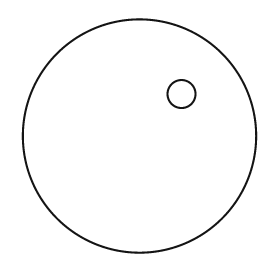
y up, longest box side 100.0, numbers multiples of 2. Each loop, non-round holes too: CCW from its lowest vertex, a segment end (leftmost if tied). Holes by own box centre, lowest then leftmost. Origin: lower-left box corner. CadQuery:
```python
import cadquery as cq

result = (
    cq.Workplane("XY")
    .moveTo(50.0, 50.0)
    .circle(50.0)
    .moveTo(68.0, 68.0)
    .circle(6.0)
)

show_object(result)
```